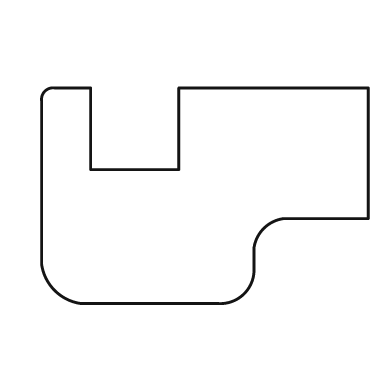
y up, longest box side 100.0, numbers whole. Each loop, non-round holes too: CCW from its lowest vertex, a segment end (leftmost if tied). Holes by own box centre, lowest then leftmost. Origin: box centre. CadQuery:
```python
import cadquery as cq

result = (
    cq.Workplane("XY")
    .moveTo(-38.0, -33.0)
    .lineTo(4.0, -33.0)
    .threePointArc((12.0, -30.0), (15.0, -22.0))
    .lineTo(15.0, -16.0)
    .threePointArc((18.0, -10.0), (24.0, -7.0))
    .lineTo(50.0, -7.0)
    .lineTo(50.0, 33.0)
    .lineTo(-8.0, 33.0)
    .lineTo(-8.0, 8.0)
    .lineTo(-35.0, 8.0)
    .lineTo(-35.0, 33.0)
    .lineTo(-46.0, 33.0)
    .threePointArc((-49.0, 32.0), (-50.0, 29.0))
    .lineTo(-50.0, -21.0)
    .threePointArc((-46.0, -29.0), (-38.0, -33.0))
    .close()
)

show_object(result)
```